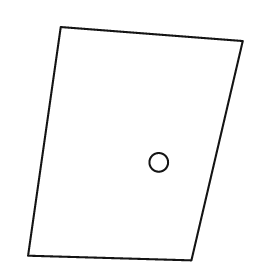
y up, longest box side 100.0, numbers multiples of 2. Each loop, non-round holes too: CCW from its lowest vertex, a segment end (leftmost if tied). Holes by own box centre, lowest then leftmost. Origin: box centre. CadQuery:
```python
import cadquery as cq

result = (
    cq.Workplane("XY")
    .moveTo(24.0, -50.0)
    .lineTo(46.0, 44.0)
    .lineTo(-32.0, 50.0)
    .lineTo(-46.0, -48.0)
    .close()
    .moveTo(10.0, -8.0)
    .circle(4.0)
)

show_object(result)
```